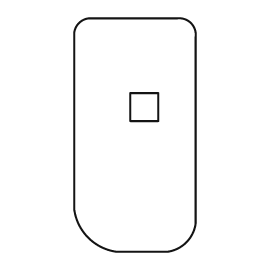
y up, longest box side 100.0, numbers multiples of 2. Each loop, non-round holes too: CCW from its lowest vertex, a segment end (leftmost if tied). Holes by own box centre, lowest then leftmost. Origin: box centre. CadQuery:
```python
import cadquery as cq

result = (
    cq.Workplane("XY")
    .moveTo(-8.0, -50.0)
    .lineTo(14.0, -50.0)
    .threePointArc((22.0, -46.0), (26.0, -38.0))
    .lineTo(26.0, 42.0)
    .threePointArc((24.0, 48.0), (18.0, 50.0))
    .lineTo(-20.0, 50.0)
    .threePointArc((-24.0, 48.0), (-26.0, 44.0))
    .lineTo(-26.0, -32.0)
    .threePointArc((-20.0, -44.0), (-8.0, -50.0))
    .close()
    .moveTo(-2.0, 6.0)
    .lineTo(10.0, 6.0)
    .lineTo(10.0, 18.0)
    .lineTo(-2.0, 18.0)
    .close()
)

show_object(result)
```